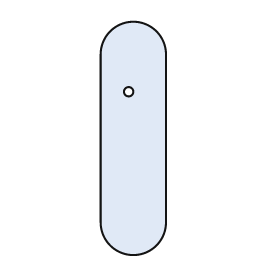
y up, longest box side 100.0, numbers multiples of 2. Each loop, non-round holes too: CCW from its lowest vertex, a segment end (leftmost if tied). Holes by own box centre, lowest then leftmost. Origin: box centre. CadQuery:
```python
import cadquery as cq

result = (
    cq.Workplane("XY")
    .moveTo(-14.0, -36.0)
    .threePointArc((0.0, -50.0), (14.0, -36.0))
    .lineTo(14.0, 36.0)
    .threePointArc((0.0, 50.0), (-14.0, 36.0))
    .close()
    .moveTo(-2.0, 20.0)
    .circle(2.0)
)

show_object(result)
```